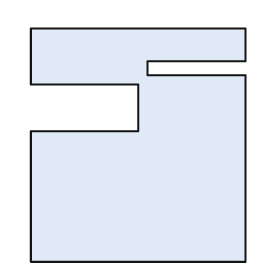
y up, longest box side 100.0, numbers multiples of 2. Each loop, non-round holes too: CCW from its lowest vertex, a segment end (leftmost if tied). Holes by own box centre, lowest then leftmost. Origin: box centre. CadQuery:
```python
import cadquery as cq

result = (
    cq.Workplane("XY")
    .moveTo(-46.0, -50.0)
    .lineTo(46.0, -50.0)
    .lineTo(46.0, 30.0)
    .lineTo(4.0, 30.0)
    .lineTo(4.0, 36.0)
    .lineTo(46.0, 36.0)
    .lineTo(46.0, 50.0)
    .lineTo(-46.0, 50.0)
    .lineTo(-46.0, 26.0)
    .lineTo(0.0, 26.0)
    .lineTo(0.0, 6.0)
    .lineTo(-46.0, 6.0)
    .close()
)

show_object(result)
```